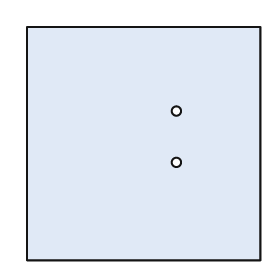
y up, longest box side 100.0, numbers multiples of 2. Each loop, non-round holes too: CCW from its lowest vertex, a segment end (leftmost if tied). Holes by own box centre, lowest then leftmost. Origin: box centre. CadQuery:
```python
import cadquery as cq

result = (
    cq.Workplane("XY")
    .moveTo(-50.0, -50.0)
    .lineTo(50.0, -50.0)
    .lineTo(50.0, 50.0)
    .lineTo(-50.0, 50.0)
    .close()
    .moveTo(14.0, -8.0)
    .circle(2.0)
    .moveTo(14.0, 14.0)
    .circle(2.0)
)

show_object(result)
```